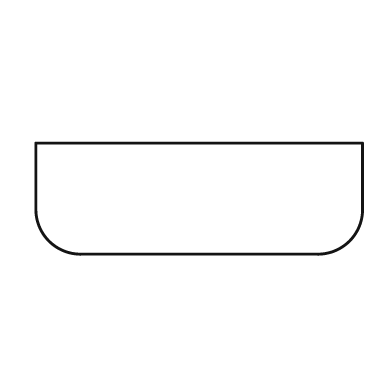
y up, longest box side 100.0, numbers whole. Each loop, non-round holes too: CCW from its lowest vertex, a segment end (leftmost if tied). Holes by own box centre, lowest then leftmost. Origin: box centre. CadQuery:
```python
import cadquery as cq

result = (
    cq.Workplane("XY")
    .moveTo(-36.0, -17.0)
    .lineTo(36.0, -17.0)
    .threePointArc((46.0, -13.0), (50.0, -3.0))
    .lineTo(50.0, 17.0)
    .lineTo(-50.0, 17.0)
    .lineTo(-50.0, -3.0)
    .threePointArc((-46.0, -13.0), (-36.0, -17.0))
    .close()
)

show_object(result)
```